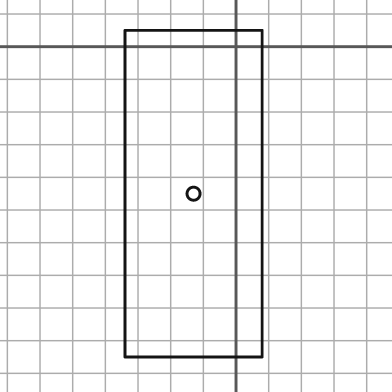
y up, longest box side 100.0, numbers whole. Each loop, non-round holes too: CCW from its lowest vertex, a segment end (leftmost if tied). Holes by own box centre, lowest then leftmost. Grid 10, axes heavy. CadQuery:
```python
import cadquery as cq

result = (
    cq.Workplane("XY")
    .moveTo(-34.0, -95.0)
    .lineTo(8.0, -95.0)
    .lineTo(8.0, 5.0)
    .lineTo(-34.0, 5.0)
    .close()
    .moveTo(-13.0, -45.0)
    .circle(2.0)
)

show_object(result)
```